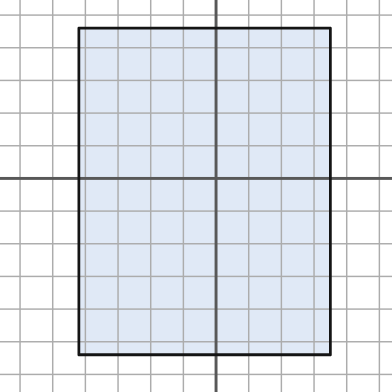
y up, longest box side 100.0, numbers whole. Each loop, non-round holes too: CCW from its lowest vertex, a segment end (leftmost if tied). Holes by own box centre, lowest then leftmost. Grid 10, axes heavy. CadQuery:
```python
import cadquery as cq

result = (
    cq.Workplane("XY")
    .moveTo(-42.0, -54.0)
    .lineTo(35.0, -54.0)
    .lineTo(35.0, 46.0)
    .lineTo(-42.0, 46.0)
    .close()
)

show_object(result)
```